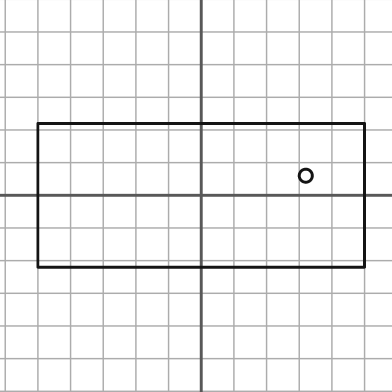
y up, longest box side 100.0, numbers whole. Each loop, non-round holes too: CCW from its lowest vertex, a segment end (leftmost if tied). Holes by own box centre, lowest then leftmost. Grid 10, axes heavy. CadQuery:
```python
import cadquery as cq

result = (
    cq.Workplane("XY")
    .moveTo(-50.0, -22.0)
    .lineTo(50.0, -22.0)
    .lineTo(50.0, 22.0)
    .lineTo(-50.0, 22.0)
    .close()
    .moveTo(32.0, 6.0)
    .circle(2.0)
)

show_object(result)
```